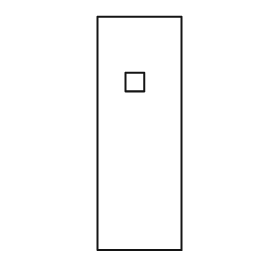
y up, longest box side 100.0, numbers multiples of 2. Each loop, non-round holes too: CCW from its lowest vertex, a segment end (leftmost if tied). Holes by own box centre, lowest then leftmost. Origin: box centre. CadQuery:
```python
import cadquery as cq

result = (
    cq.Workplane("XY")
    .moveTo(-18.0, -50.0)
    .lineTo(18.0, -50.0)
    .lineTo(18.0, 50.0)
    .lineTo(-18.0, 50.0)
    .close()
    .moveTo(-6.0, 18.0)
    .lineTo(2.0, 18.0)
    .lineTo(2.0, 26.0)
    .lineTo(-6.0, 26.0)
    .close()
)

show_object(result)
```